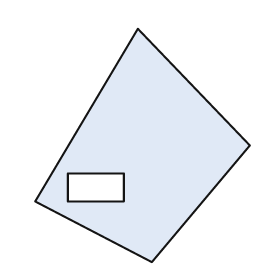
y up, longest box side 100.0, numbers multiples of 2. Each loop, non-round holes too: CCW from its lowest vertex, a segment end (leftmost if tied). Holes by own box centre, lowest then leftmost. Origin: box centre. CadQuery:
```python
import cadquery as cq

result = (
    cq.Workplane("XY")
    .moveTo(4.0, -50.0)
    .lineTo(46.0, 0.0)
    .lineTo(-2.0, 50.0)
    .lineTo(-46.0, -24.0)
    .close()
    .moveTo(-32.0, -24.0)
    .lineTo(-8.0, -24.0)
    .lineTo(-8.0, -12.0)
    .lineTo(-32.0, -12.0)
    .close()
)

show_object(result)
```